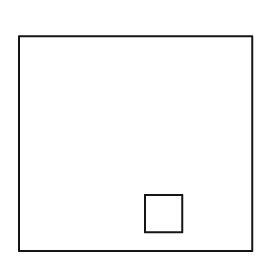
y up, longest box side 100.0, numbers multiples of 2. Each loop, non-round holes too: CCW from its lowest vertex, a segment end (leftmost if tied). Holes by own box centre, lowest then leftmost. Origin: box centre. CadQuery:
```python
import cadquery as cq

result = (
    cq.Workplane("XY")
    .moveTo(-50.0, -46.0)
    .lineTo(50.0, -46.0)
    .lineTo(50.0, 46.0)
    .lineTo(-50.0, 46.0)
    .close()
    .moveTo(4.0, -38.0)
    .lineTo(20.0, -38.0)
    .lineTo(20.0, -22.0)
    .lineTo(4.0, -22.0)
    .close()
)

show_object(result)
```